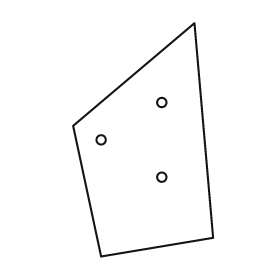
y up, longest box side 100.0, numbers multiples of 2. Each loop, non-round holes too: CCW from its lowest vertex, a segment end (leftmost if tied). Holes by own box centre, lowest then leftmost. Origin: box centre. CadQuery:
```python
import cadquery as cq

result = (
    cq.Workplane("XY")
    .moveTo(-18.0, -50.0)
    .lineTo(30.0, -42.0)
    .lineTo(22.0, 50.0)
    .lineTo(-30.0, 6.0)
    .close()
    .moveTo(8.0, -16.0)
    .circle(2.0)
    .moveTo(-18.0, 0.0)
    .circle(2.0)
    .moveTo(8.0, 16.0)
    .circle(2.0)
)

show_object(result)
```